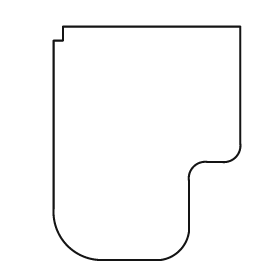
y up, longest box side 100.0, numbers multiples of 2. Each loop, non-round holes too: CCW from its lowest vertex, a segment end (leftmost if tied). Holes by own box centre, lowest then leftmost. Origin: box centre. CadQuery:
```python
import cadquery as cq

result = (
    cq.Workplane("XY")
    .moveTo(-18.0, -50.0)
    .lineTo(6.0, -50.0)
    .threePointArc((14.0, -46.0), (18.0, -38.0))
    .lineTo(18.0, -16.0)
    .threePointArc((20.0, -10.0), (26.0, -8.0))
    .lineTo(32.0, -8.0)
    .threePointArc((38.0, -6.0), (40.0, 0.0))
    .lineTo(40.0, 50.0)
    .lineTo(-36.0, 50.0)
    .lineTo(-36.0, 44.0)
    .lineTo(-40.0, 44.0)
    .lineTo(-40.0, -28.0)
    .threePointArc((-34.0, -44.0), (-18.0, -50.0))
    .close()
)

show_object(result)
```